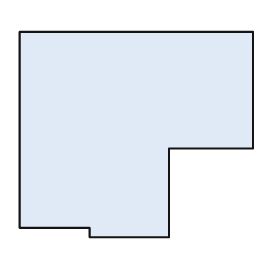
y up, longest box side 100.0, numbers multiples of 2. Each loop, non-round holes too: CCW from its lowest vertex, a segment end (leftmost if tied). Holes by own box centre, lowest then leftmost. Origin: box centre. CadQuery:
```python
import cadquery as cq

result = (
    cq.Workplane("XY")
    .moveTo(-20.0, -44.0)
    .lineTo(14.0, -44.0)
    .lineTo(14.0, -6.0)
    .lineTo(50.0, -6.0)
    .lineTo(50.0, 44.0)
    .lineTo(-50.0, 44.0)
    .lineTo(-50.0, -40.0)
    .lineTo(-20.0, -40.0)
    .close()
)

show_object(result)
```